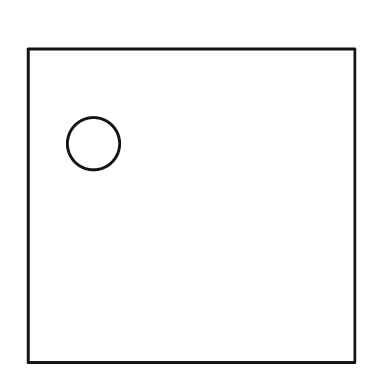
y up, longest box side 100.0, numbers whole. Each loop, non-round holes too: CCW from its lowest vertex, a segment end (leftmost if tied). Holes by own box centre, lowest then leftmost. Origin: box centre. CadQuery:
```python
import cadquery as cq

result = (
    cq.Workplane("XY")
    .moveTo(-50.0, -48.0)
    .lineTo(50.0, -48.0)
    .lineTo(50.0, 48.0)
    .lineTo(-50.0, 48.0)
    .close()
    .moveTo(-30.0, 19.0)
    .circle(8.0)
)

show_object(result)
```